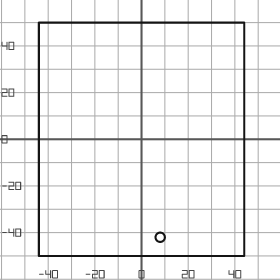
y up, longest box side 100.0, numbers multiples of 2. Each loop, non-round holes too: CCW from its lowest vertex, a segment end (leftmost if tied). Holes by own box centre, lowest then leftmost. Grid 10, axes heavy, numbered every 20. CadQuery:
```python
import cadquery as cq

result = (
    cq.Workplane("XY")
    .moveTo(-44.0, -50.0)
    .lineTo(44.0, -50.0)
    .lineTo(44.0, 50.0)
    .lineTo(-44.0, 50.0)
    .close()
    .moveTo(8.0, -42.0)
    .circle(2.0)
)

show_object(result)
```